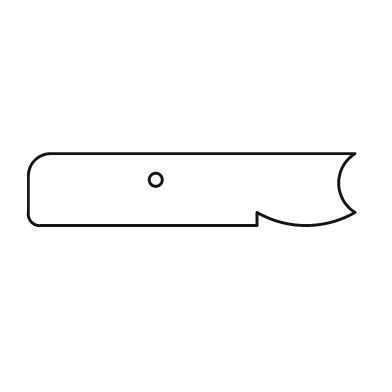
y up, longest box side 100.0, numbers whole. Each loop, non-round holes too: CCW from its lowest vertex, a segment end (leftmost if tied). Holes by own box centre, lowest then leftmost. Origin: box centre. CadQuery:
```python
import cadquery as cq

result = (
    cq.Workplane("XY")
    .moveTo(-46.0, -11.0)
    .lineTo(20.0, -11.0)
    .lineTo(20.0, -7.0)
    .threePointArc((35.0, -11.0), (50.0, -7.0))
    .threePointArc((45.0, 2.0), (50.0, 11.0))
    .lineTo(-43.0, 11.0)
    .threePointArc((-48.0, 9.0), (-50.0, 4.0))
    .lineTo(-50.0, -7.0)
    .threePointArc((-49.0, -10.0), (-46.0, -11.0))
    .close()
    .moveTo(-11.0, 3.0)
    .circle(2.0)
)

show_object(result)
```